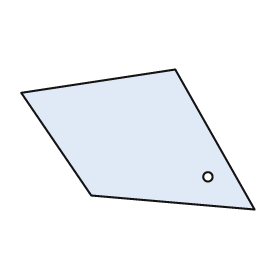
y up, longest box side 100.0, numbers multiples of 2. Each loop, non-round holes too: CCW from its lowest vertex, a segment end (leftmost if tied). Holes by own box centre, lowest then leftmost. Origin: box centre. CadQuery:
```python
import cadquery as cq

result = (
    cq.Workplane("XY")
    .moveTo(50.0, -30.0)
    .lineTo(16.0, 30.0)
    .lineTo(-50.0, 20.0)
    .lineTo(-20.0, -24.0)
    .close()
    .moveTo(30.0, -16.0)
    .circle(2.0)
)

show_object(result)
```